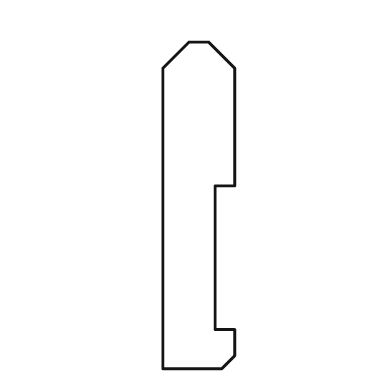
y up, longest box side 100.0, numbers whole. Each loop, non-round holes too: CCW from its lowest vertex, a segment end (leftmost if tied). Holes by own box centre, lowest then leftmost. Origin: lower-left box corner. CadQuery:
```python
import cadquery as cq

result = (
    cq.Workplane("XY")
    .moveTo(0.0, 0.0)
    .lineTo(18.0, 0.0)
    .lineTo(22.0, 4.0)
    .lineTo(22.0, 12.0)
    .lineTo(16.0, 12.0)
    .lineTo(16.0, 56.0)
    .lineTo(22.0, 56.0)
    .lineTo(22.0, 92.0)
    .lineTo(14.0, 100.0)
    .lineTo(8.0, 100.0)
    .lineTo(0.0, 92.0)
    .close()
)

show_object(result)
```